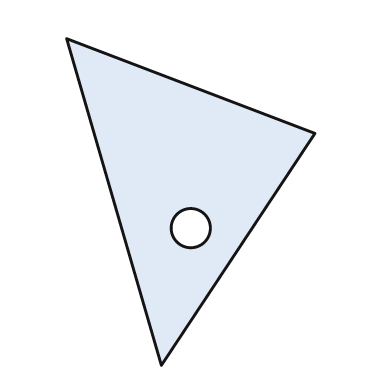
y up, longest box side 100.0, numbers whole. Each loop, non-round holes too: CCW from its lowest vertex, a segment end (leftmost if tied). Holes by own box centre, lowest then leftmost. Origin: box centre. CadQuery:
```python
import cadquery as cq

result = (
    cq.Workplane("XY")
    .moveTo(-9.0, -50.0)
    .lineTo(38.0, 21.0)
    .lineTo(-38.0, 50.0)
    .close()
    .moveTo(0.0, -8.0)
    .circle(6.0)
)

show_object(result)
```